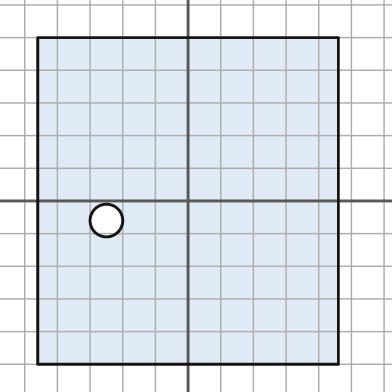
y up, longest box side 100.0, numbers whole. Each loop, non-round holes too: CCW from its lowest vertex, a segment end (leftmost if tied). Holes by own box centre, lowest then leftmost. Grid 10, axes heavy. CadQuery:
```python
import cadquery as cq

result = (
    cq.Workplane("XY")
    .moveTo(-46.0, -50.0)
    .lineTo(46.0, -50.0)
    .lineTo(46.0, 50.0)
    .lineTo(-46.0, 50.0)
    .close()
    .moveTo(-25.0, -6.0)
    .circle(5.0)
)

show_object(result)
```